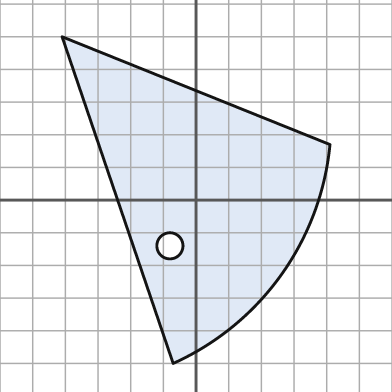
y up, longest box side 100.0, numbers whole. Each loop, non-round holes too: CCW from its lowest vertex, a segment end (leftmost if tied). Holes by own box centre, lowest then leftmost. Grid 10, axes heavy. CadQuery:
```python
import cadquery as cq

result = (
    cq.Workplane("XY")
    .moveTo(-7.0, -50.0)
    .threePointArc((26.0, -23.0), (41.0, 17.0))
    .lineTo(-41.0, 50.0)
    .close()
    .moveTo(-8.0, -14.0)
    .circle(4.0)
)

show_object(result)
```